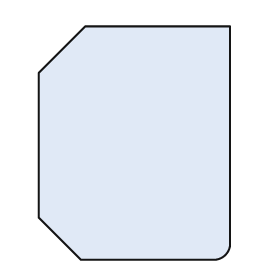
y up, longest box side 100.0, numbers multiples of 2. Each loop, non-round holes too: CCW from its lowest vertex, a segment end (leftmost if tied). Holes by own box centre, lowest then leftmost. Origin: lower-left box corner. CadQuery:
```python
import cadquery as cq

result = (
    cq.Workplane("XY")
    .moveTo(18.0, 0.0)
    .lineTo(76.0, 0.0)
    .threePointArc((80.0, 2.0), (82.0, 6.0))
    .lineTo(82.0, 100.0)
    .lineTo(20.0, 100.0)
    .lineTo(0.0, 80.0)
    .lineTo(0.0, 18.0)
    .close()
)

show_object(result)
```